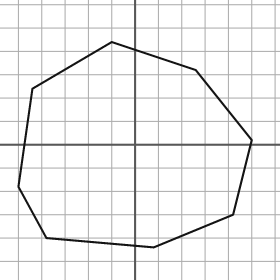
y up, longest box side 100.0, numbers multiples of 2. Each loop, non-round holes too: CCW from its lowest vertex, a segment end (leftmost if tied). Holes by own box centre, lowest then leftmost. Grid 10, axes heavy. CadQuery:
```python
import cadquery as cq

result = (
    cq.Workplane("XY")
    .moveTo(8.0, -44.0)
    .lineTo(42.0, -30.0)
    .lineTo(50.0, 2.0)
    .lineTo(26.0, 32.0)
    .lineTo(-10.0, 44.0)
    .lineTo(-44.0, 24.0)
    .lineTo(-50.0, -18.0)
    .lineTo(-38.0, -40.0)
    .close()
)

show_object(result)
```